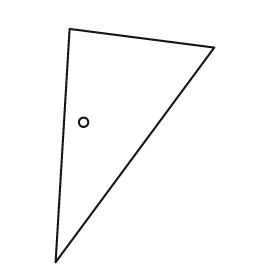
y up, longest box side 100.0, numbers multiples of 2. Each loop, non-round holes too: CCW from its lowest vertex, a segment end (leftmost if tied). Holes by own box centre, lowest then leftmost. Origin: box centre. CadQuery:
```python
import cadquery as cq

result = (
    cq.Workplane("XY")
    .moveTo(-34.0, -50.0)
    .lineTo(34.0, 42.0)
    .lineTo(-28.0, 50.0)
    .close()
    .moveTo(-22.0, 10.0)
    .circle(2.0)
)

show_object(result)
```